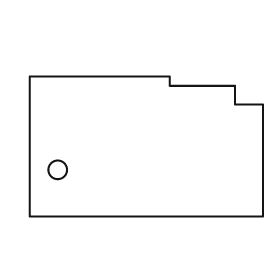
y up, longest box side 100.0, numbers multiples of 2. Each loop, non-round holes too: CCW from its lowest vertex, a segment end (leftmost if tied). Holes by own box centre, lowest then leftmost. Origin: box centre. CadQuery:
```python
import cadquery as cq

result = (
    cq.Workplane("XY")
    .moveTo(-50.0, -30.0)
    .lineTo(50.0, -30.0)
    .lineTo(50.0, 18.0)
    .lineTo(38.0, 18.0)
    .lineTo(38.0, 26.0)
    .lineTo(10.0, 26.0)
    .lineTo(10.0, 30.0)
    .lineTo(-50.0, 30.0)
    .close()
    .moveTo(-38.0, -10.0)
    .circle(4.0)
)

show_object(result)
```